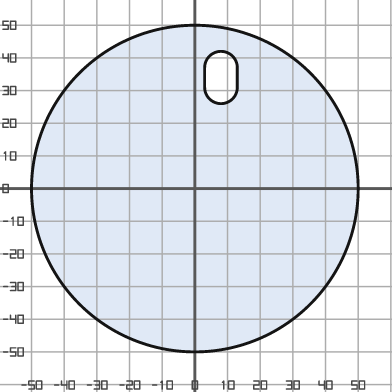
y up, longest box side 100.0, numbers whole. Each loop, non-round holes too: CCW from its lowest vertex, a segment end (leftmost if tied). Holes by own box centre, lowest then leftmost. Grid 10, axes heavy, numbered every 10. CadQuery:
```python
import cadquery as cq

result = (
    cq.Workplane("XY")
    .moveTo(0.0, 0.0)
    .circle(50.0)
    .moveTo(3.0, 31.0)
    .threePointArc((8.0, 26.0), (13.0, 31.0))
    .lineTo(13.0, 37.0)
    .threePointArc((8.0, 42.0), (3.0, 37.0))
    .close()
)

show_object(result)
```